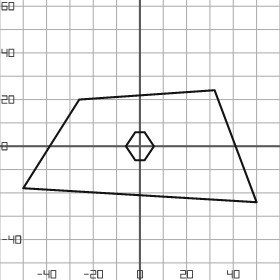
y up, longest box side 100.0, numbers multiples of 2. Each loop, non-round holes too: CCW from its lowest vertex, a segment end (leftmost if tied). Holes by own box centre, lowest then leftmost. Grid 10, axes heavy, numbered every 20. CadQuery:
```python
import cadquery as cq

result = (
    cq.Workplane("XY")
    .moveTo(50.0, -24.0)
    .lineTo(32.0, 24.0)
    .lineTo(-26.0, 20.0)
    .lineTo(-50.0, -18.0)
    .close()
    .moveTo(-2.0, -6.0)
    .lineTo(2.0, -6.0)
    .lineTo(6.0, 0.0)
    .lineTo(2.0, 6.0)
    .lineTo(-2.0, 6.0)
    .lineTo(-6.0, 0.0)
    .close()
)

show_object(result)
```